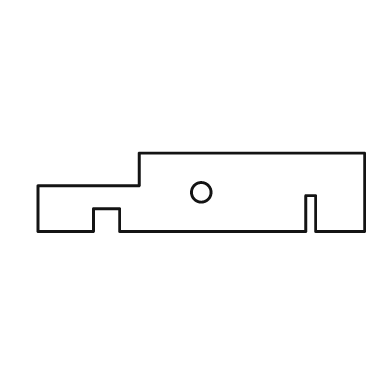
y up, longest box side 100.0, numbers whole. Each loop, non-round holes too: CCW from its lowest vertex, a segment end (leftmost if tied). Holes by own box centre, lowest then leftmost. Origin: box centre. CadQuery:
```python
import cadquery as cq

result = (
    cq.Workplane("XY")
    .moveTo(-50.0, -12.0)
    .lineTo(-33.0, -12.0)
    .lineTo(-33.0, -5.0)
    .lineTo(-25.0, -5.0)
    .lineTo(-25.0, -12.0)
    .lineTo(32.0, -12.0)
    .lineTo(32.0, -1.0)
    .lineTo(35.0, -1.0)
    .lineTo(35.0, -12.0)
    .lineTo(50.0, -12.0)
    .lineTo(50.0, 12.0)
    .lineTo(-19.0, 12.0)
    .lineTo(-19.0, 2.0)
    .lineTo(-50.0, 2.0)
    .close()
    .moveTo(0.0, 0.0)
    .circle(3.0)
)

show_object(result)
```